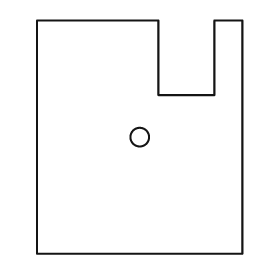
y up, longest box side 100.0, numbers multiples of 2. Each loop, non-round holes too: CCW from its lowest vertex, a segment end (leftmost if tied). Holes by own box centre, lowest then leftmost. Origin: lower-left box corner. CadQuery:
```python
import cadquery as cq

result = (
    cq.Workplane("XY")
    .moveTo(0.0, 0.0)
    .lineTo(88.0, 0.0)
    .lineTo(88.0, 100.0)
    .lineTo(76.0, 100.0)
    .lineTo(76.0, 68.0)
    .lineTo(52.0, 68.0)
    .lineTo(52.0, 100.0)
    .lineTo(0.0, 100.0)
    .close()
    .moveTo(44.0, 50.0)
    .circle(4.0)
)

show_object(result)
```